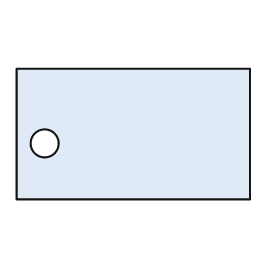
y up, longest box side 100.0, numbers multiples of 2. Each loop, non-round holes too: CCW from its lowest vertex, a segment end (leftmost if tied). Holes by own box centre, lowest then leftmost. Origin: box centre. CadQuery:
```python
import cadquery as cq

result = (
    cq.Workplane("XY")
    .moveTo(-50.0, -28.0)
    .lineTo(50.0, -28.0)
    .lineTo(50.0, 28.0)
    .lineTo(-50.0, 28.0)
    .close()
    .moveTo(-38.0, -4.0)
    .circle(6.0)
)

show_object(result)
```